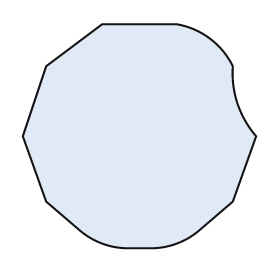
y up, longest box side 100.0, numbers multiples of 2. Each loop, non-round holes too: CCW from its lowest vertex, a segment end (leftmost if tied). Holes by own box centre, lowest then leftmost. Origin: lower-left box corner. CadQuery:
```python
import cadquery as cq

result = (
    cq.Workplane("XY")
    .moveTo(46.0, 0.0)
    .lineTo(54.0, 0.0)
    .threePointArc((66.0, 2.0), (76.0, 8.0))
    .lineTo(90.0, 20.0)
    .lineTo(100.0, 48.0)
    .threePointArc((92.0, 62.0), (90.0, 78.0))
    .threePointArc((80.0, 90.0), (66.0, 96.0))
    .lineTo(34.0, 96.0)
    .lineTo(10.0, 78.0)
    .lineTo(0.0, 48.0)
    .lineTo(10.0, 20.0)
    .lineTo(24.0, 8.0)
    .threePointArc((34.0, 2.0), (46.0, 0.0))
    .close()
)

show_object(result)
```